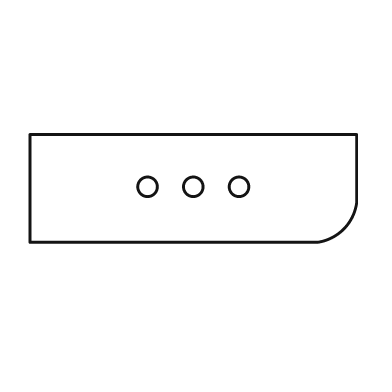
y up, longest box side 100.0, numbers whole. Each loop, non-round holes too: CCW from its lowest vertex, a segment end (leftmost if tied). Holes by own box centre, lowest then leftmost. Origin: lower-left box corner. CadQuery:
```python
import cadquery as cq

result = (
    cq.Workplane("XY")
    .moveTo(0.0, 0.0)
    .lineTo(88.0, 0.0)
    .threePointArc((96.0, 4.0), (100.0, 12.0))
    .lineTo(100.0, 33.0)
    .lineTo(0.0, 33.0)
    .close()
    .moveTo(36.0, 17.0)
    .circle(3.0)
    .moveTo(50.0, 17.0)
    .circle(3.0)
    .moveTo(64.0, 17.0)
    .circle(3.0)
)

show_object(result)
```